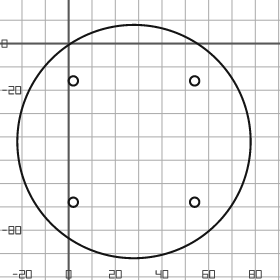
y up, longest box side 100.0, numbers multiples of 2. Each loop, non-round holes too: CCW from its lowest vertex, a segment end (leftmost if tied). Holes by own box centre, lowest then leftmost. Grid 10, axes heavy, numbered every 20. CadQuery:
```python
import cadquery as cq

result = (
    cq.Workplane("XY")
    .moveTo(28.0, -42.0)
    .circle(50.0)
    .moveTo(2.0, -68.0)
    .circle(2.0)
    .moveTo(54.0, -68.0)
    .circle(2.0)
    .moveTo(2.0, -16.0)
    .circle(2.0)
    .moveTo(54.0, -16.0)
    .circle(2.0)
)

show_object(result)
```